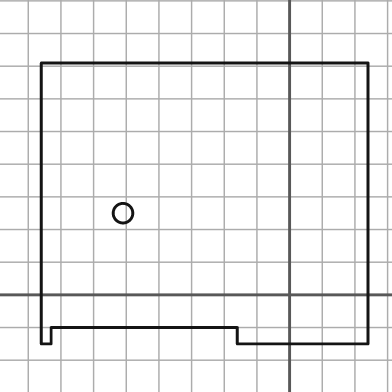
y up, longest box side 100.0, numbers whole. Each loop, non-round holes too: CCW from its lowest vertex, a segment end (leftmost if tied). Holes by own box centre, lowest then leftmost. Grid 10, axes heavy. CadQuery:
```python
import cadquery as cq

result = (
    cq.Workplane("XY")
    .moveTo(-76.0, -15.0)
    .lineTo(-73.0, -15.0)
    .lineTo(-73.0, -10.0)
    .lineTo(-16.0, -10.0)
    .lineTo(-16.0, -15.0)
    .lineTo(24.0, -15.0)
    .lineTo(24.0, 71.0)
    .lineTo(-76.0, 71.0)
    .close()
    .moveTo(-51.0, 25.0)
    .circle(3.0)
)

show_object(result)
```